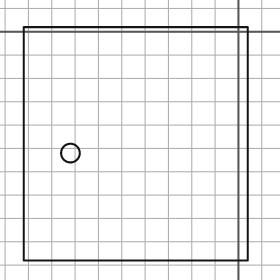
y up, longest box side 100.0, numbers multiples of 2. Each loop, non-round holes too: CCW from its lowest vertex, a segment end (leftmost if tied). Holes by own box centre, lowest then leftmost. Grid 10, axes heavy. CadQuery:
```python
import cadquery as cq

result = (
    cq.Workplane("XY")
    .moveTo(-92.0, -98.0)
    .lineTo(4.0, -98.0)
    .lineTo(4.0, 2.0)
    .lineTo(-92.0, 2.0)
    .close()
    .moveTo(-72.0, -52.0)
    .circle(4.0)
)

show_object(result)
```